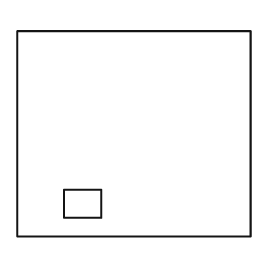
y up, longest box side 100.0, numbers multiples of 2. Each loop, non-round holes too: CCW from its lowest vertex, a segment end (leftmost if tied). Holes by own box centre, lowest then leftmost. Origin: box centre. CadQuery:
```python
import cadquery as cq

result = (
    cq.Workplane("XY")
    .moveTo(-50.0, -44.0)
    .lineTo(50.0, -44.0)
    .lineTo(50.0, 44.0)
    .lineTo(-50.0, 44.0)
    .close()
    .moveTo(-30.0, -36.0)
    .lineTo(-14.0, -36.0)
    .lineTo(-14.0, -24.0)
    .lineTo(-30.0, -24.0)
    .close()
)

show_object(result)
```